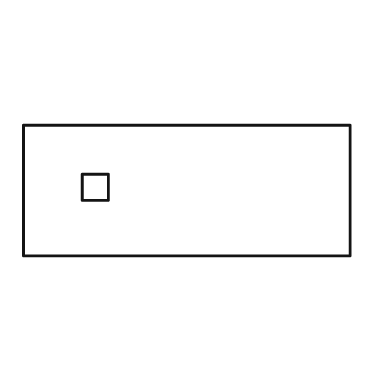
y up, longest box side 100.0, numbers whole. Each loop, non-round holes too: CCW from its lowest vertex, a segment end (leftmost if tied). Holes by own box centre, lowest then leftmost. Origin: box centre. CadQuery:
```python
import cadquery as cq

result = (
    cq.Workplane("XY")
    .moveTo(-50.0, -20.0)
    .lineTo(50.0, -20.0)
    .lineTo(50.0, 20.0)
    .lineTo(-50.0, 20.0)
    .close()
    .moveTo(-32.0, -3.0)
    .lineTo(-24.0, -3.0)
    .lineTo(-24.0, 5.0)
    .lineTo(-32.0, 5.0)
    .close()
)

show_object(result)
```